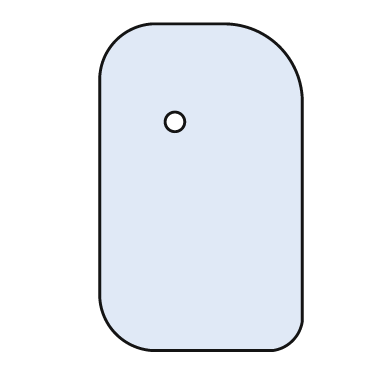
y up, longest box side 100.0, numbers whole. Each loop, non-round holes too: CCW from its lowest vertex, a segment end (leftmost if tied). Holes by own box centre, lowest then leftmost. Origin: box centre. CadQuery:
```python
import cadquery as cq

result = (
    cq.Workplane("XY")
    .moveTo(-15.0, -50.0)
    .lineTo(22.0, -50.0)
    .threePointArc((28.0, -47.0), (31.0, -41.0))
    .lineTo(31.0, 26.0)
    .threePointArc((24.0, 43.0), (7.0, 50.0))
    .lineTo(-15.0, 50.0)
    .threePointArc((-26.0, 45.0), (-31.0, 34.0))
    .lineTo(-31.0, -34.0)
    .threePointArc((-26.0, -45.0), (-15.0, -50.0))
    .close()
    .moveTo(-8.0, 20.0)
    .circle(3.0)
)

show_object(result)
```